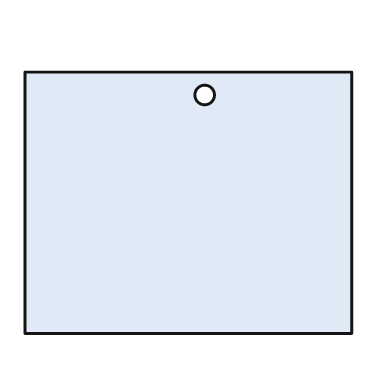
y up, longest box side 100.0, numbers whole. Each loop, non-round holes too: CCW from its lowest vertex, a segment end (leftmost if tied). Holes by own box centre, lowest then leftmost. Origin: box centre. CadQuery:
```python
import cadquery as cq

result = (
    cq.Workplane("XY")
    .moveTo(-50.0, -40.0)
    .lineTo(50.0, -40.0)
    .lineTo(50.0, 40.0)
    .lineTo(-50.0, 40.0)
    .close()
    .moveTo(5.0, 33.0)
    .circle(3.0)
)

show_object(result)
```